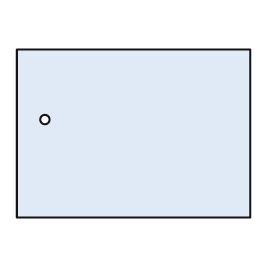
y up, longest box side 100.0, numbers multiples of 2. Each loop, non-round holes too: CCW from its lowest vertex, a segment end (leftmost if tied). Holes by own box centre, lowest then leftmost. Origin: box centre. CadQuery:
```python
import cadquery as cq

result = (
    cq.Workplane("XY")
    .moveTo(-50.0, -36.0)
    .lineTo(50.0, -36.0)
    .lineTo(50.0, 36.0)
    .lineTo(-50.0, 36.0)
    .close()
    .moveTo(-38.0, 6.0)
    .circle(2.0)
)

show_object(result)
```